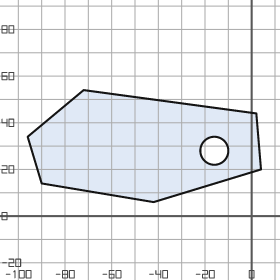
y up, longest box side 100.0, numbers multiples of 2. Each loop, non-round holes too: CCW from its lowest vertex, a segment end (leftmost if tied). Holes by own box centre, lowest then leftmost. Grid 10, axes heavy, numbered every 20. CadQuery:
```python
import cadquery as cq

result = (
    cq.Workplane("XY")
    .moveTo(-42.0, 6.0)
    .lineTo(4.0, 20.0)
    .lineTo(2.0, 44.0)
    .lineTo(-72.0, 54.0)
    .lineTo(-96.0, 34.0)
    .lineTo(-90.0, 14.0)
    .close()
    .moveTo(-16.0, 28.0)
    .circle(6.0)
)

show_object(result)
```